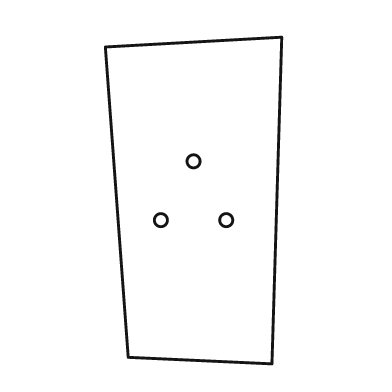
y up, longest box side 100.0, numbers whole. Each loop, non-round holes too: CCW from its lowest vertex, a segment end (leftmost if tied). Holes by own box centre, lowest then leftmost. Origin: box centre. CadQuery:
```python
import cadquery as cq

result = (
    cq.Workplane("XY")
    .moveTo(24.0, -50.0)
    .lineTo(27.0, 50.0)
    .lineTo(-27.0, 47.0)
    .lineTo(-20.0, -48.0)
    .close()
    .moveTo(-10.0, -6.0)
    .circle(2.0)
    .moveTo(10.0, -6.0)
    .circle(2.0)
    .moveTo(0.0, 12.0)
    .circle(2.0)
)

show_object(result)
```